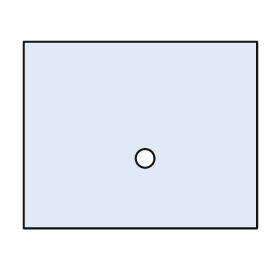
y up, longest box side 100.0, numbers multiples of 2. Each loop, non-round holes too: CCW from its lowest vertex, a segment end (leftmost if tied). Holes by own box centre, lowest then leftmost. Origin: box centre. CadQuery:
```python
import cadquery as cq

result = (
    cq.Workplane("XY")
    .moveTo(-50.0, -40.0)
    .lineTo(50.0, -40.0)
    .lineTo(50.0, 40.0)
    .lineTo(-50.0, 40.0)
    .close()
    .moveTo(2.0, -10.0)
    .circle(4.0)
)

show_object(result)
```